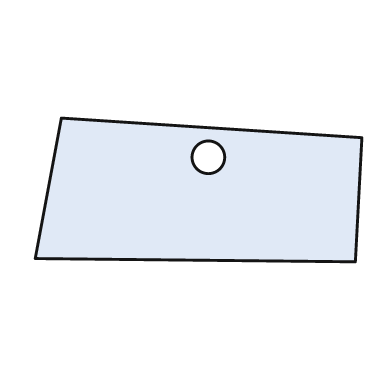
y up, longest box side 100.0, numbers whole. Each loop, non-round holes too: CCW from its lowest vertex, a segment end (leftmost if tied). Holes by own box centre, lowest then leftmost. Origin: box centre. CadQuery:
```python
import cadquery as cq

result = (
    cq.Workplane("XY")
    .moveTo(48.0, -22.0)
    .lineTo(50.0, 16.0)
    .lineTo(-42.0, 22.0)
    .lineTo(-50.0, -21.0)
    .close()
    .moveTo(3.0, 10.0)
    .circle(5.0)
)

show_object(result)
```